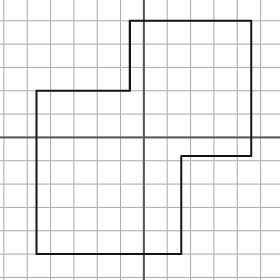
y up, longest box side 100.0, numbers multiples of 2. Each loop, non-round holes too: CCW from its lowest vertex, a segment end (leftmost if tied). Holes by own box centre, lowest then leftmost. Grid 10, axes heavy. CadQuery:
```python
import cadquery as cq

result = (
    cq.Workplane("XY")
    .moveTo(-46.0, -50.0)
    .lineTo(16.0, -50.0)
    .lineTo(16.0, -8.0)
    .lineTo(46.0, -8.0)
    .lineTo(46.0, 50.0)
    .lineTo(-6.0, 50.0)
    .lineTo(-6.0, 20.0)
    .lineTo(-46.0, 20.0)
    .close()
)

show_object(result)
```